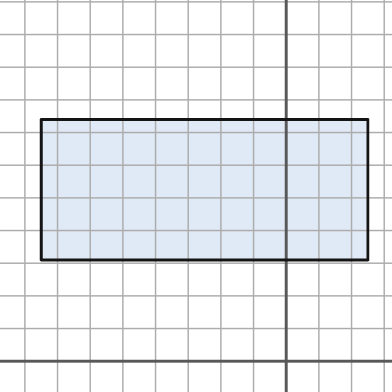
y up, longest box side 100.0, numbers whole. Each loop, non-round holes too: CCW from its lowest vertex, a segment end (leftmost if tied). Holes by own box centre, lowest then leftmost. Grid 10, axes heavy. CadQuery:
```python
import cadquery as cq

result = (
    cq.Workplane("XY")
    .moveTo(-75.0, 31.0)
    .lineTo(25.0, 31.0)
    .lineTo(25.0, 74.0)
    .lineTo(-75.0, 74.0)
    .close()
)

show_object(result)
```